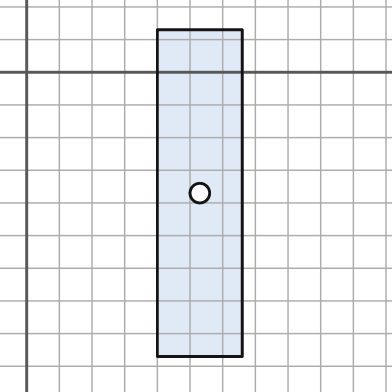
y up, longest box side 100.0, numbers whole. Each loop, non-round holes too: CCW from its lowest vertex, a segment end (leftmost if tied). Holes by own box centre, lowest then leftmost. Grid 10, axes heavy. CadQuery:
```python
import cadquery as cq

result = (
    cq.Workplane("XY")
    .moveTo(40.0, -87.0)
    .lineTo(66.0, -87.0)
    .lineTo(66.0, 13.0)
    .lineTo(40.0, 13.0)
    .close()
    .moveTo(53.0, -37.0)
    .circle(3.0)
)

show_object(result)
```